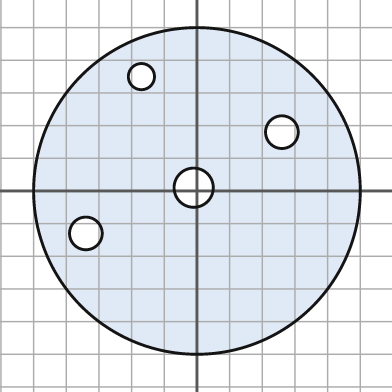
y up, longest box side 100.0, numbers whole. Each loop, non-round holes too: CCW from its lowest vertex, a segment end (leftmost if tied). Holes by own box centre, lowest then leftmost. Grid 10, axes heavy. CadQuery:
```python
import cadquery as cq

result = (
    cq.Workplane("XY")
    .moveTo(0.0, 0.0)
    .circle(50.0)
    .moveTo(-34.0, -13.0)
    .circle(5.0)
    .moveTo(-1.0, 1.0)
    .circle(6.0)
    .moveTo(26.0, 18.0)
    .circle(5.0)
    .moveTo(-17.0, 35.0)
    .circle(4.0)
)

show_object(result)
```